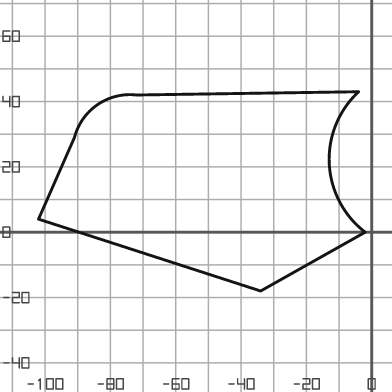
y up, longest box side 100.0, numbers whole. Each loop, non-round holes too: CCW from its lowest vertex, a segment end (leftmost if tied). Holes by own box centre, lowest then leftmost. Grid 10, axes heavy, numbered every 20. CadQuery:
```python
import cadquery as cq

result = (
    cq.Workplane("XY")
    .moveTo(-34.0, -18.0)
    .lineTo(-2.0, 0.0)
    .threePointArc((-13.0, 21.0), (-4.0, 43.0))
    .lineTo(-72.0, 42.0)
    .threePointArc((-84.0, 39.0), (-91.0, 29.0))
    .lineTo(-102.0, 4.0)
    .close()
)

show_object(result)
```